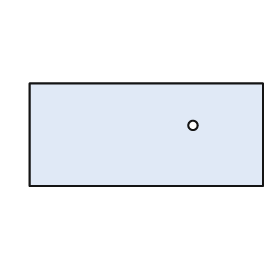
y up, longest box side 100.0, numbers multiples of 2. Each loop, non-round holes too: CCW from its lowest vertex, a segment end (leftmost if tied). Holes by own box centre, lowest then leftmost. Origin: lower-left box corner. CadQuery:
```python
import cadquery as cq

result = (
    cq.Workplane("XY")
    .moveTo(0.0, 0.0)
    .lineTo(100.0, 0.0)
    .lineTo(100.0, 44.0)
    .lineTo(0.0, 44.0)
    .close()
    .moveTo(70.0, 26.0)
    .circle(2.0)
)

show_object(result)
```